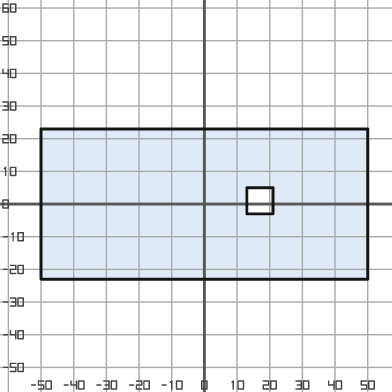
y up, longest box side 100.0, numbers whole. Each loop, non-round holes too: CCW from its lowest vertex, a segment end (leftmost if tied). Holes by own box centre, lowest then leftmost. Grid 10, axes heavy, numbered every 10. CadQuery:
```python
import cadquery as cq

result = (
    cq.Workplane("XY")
    .moveTo(-50.0, -23.0)
    .lineTo(50.0, -23.0)
    .lineTo(50.0, 23.0)
    .lineTo(-50.0, 23.0)
    .close()
    .moveTo(13.0, -3.0)
    .lineTo(21.0, -3.0)
    .lineTo(21.0, 5.0)
    .lineTo(13.0, 5.0)
    .close()
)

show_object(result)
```